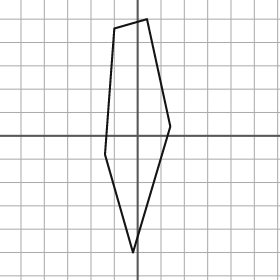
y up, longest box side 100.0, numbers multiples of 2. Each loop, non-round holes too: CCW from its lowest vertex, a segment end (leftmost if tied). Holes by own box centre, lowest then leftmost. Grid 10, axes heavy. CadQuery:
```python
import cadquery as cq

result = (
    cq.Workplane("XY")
    .moveTo(-2.0, -50.0)
    .lineTo(14.0, 4.0)
    .lineTo(4.0, 50.0)
    .lineTo(-10.0, 46.0)
    .lineTo(-14.0, -8.0)
    .close()
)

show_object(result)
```